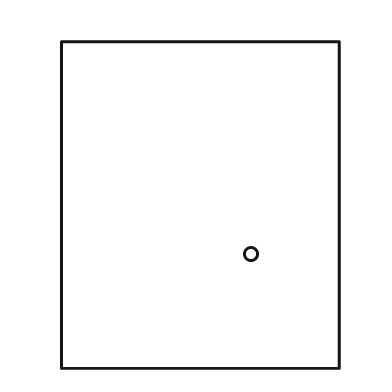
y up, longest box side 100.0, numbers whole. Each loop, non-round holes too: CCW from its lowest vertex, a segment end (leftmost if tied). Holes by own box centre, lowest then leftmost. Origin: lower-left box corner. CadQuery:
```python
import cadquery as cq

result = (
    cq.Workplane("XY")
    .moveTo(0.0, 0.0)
    .lineTo(85.0, 0.0)
    .lineTo(85.0, 100.0)
    .lineTo(0.0, 100.0)
    .close()
    .moveTo(58.0, 35.0)
    .circle(2.0)
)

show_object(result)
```